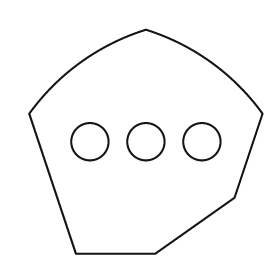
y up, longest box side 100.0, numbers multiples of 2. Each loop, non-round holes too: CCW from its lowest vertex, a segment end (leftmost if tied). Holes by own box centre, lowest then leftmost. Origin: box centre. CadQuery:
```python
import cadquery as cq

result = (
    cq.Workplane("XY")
    .moveTo(-30.0, -48.0)
    .lineTo(4.0, -48.0)
    .lineTo(38.0, -24.0)
    .lineTo(50.0, 12.0)
    .threePointArc((28.0, 34.0), (0.0, 48.0))
    .threePointArc((-28.0, 34.0), (-50.0, 12.0))
    .close()
    .moveTo(-24.0, 0.0)
    .circle(8.0)
    .moveTo(0.0, 0.0)
    .circle(8.0)
    .moveTo(24.0, 0.0)
    .circle(8.0)
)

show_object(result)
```